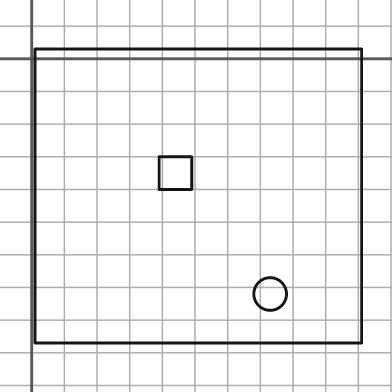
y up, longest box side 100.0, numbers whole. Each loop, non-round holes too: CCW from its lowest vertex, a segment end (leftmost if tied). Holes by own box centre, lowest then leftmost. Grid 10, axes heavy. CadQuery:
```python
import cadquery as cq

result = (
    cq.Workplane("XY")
    .moveTo(1.0, -87.0)
    .lineTo(101.0, -87.0)
    .lineTo(101.0, 3.0)
    .lineTo(1.0, 3.0)
    .close()
    .moveTo(73.0, -72.0)
    .circle(5.0)
    .moveTo(39.0, -40.0)
    .lineTo(49.0, -40.0)
    .lineTo(49.0, -30.0)
    .lineTo(39.0, -30.0)
    .close()
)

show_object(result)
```